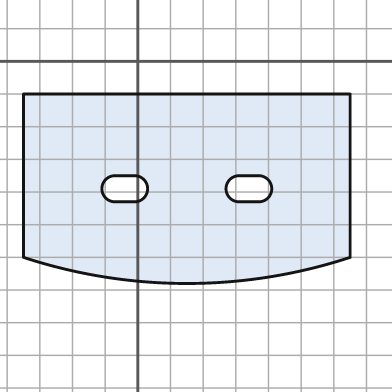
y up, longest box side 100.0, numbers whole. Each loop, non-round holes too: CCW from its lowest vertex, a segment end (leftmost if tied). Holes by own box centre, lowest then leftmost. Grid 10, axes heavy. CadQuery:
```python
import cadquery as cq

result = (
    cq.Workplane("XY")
    .moveTo(-35.0, -60.0)
    .threePointArc((15.0, -68.0), (65.0, -60.0))
    .lineTo(65.0, -10.0)
    .lineTo(-35.0, -10.0)
    .close()
    .moveTo(-7.0, -43.0)
    .lineTo(-1.0, -43.0)
    .threePointArc((3.0, -39.0), (-1.0, -35.0))
    .lineTo(-7.0, -35.0)
    .threePointArc((-11.0, -39.0), (-7.0, -43.0))
    .close()
    .moveTo(31.0, -43.0)
    .lineTo(37.0, -43.0)
    .threePointArc((41.0, -39.0), (37.0, -35.0))
    .lineTo(31.0, -35.0)
    .threePointArc((27.0, -39.0), (31.0, -43.0))
    .close()
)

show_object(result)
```